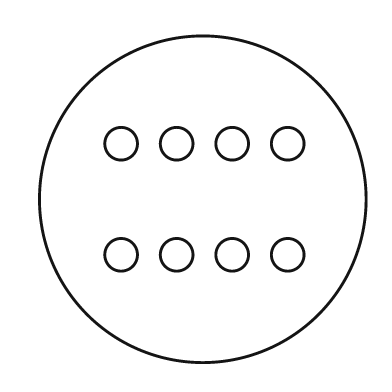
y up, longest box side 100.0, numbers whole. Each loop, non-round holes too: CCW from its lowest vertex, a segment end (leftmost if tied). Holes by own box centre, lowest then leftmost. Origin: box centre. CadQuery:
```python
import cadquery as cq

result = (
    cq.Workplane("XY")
    .moveTo(0.0, 0.0)
    .circle(50.0)
    .moveTo(-25.0, -17.0)
    .circle(5.0)
    .moveTo(-8.0, -17.0)
    .circle(5.0)
    .moveTo(9.0, -17.0)
    .circle(5.0)
    .moveTo(26.0, -17.0)
    .circle(5.0)
    .moveTo(-25.0, 17.0)
    .circle(5.0)
    .moveTo(-8.0, 17.0)
    .circle(5.0)
    .moveTo(9.0, 17.0)
    .circle(5.0)
    .moveTo(26.0, 17.0)
    .circle(5.0)
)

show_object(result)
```